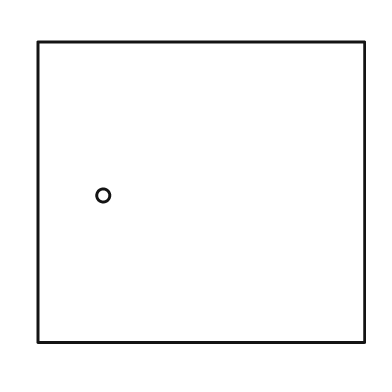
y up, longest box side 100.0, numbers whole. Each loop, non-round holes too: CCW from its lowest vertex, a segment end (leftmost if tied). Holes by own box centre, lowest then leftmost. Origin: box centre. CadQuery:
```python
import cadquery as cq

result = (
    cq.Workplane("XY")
    .moveTo(-50.0, -46.0)
    .lineTo(50.0, -46.0)
    .lineTo(50.0, 46.0)
    .lineTo(-50.0, 46.0)
    .close()
    .moveTo(-30.0, -1.0)
    .circle(2.0)
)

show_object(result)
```